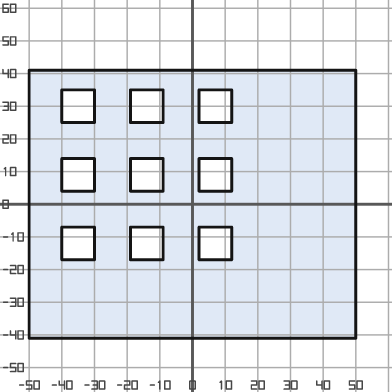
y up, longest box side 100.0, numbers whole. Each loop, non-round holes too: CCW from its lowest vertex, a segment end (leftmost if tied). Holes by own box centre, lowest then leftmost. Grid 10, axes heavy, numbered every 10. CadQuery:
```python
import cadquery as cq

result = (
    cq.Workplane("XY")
    .moveTo(-50.0, -41.0)
    .lineTo(50.0, -41.0)
    .lineTo(50.0, 41.0)
    .lineTo(-50.0, 41.0)
    .close()
    .moveTo(-40.0, -17.0)
    .lineTo(-30.0, -17.0)
    .lineTo(-30.0, -7.0)
    .lineTo(-40.0, -7.0)
    .close()
    .moveTo(-19.0, -17.0)
    .lineTo(-9.0, -17.0)
    .lineTo(-9.0, -7.0)
    .lineTo(-19.0, -7.0)
    .close()
    .moveTo(2.0, -17.0)
    .lineTo(12.0, -17.0)
    .lineTo(12.0, -7.0)
    .lineTo(2.0, -7.0)
    .close()
    .moveTo(-40.0, 4.0)
    .lineTo(-30.0, 4.0)
    .lineTo(-30.0, 14.0)
    .lineTo(-40.0, 14.0)
    .close()
    .moveTo(-19.0, 4.0)
    .lineTo(-9.0, 4.0)
    .lineTo(-9.0, 14.0)
    .lineTo(-19.0, 14.0)
    .close()
    .moveTo(2.0, 4.0)
    .lineTo(12.0, 4.0)
    .lineTo(12.0, 14.0)
    .lineTo(2.0, 14.0)
    .close()
    .moveTo(-40.0, 25.0)
    .lineTo(-30.0, 25.0)
    .lineTo(-30.0, 35.0)
    .lineTo(-40.0, 35.0)
    .close()
    .moveTo(-19.0, 25.0)
    .lineTo(-9.0, 25.0)
    .lineTo(-9.0, 35.0)
    .lineTo(-19.0, 35.0)
    .close()
    .moveTo(2.0, 25.0)
    .lineTo(12.0, 25.0)
    .lineTo(12.0, 35.0)
    .lineTo(2.0, 35.0)
    .close()
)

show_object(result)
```